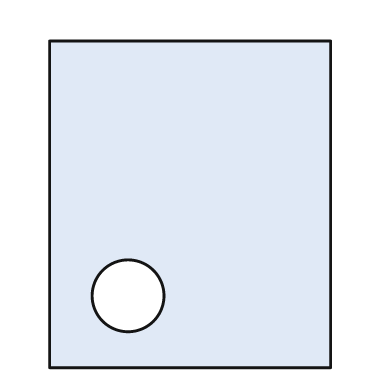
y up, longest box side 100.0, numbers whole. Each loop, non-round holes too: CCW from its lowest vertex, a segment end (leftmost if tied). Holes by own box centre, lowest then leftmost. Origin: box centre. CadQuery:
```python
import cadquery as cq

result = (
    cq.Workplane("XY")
    .moveTo(-43.0, -50.0)
    .lineTo(43.0, -50.0)
    .lineTo(43.0, 50.0)
    .lineTo(-43.0, 50.0)
    .close()
    .moveTo(-19.0, -28.0)
    .circle(11.0)
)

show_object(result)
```